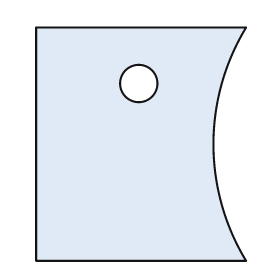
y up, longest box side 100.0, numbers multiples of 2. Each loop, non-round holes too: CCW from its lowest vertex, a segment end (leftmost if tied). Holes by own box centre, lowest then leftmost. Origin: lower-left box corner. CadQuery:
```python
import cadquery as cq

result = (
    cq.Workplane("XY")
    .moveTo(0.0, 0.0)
    .lineTo(90.0, 0.0)
    .threePointArc((76.0, 50.0), (90.0, 100.0))
    .lineTo(0.0, 100.0)
    .close()
    .moveTo(44.0, 76.0)
    .circle(8.0)
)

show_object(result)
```